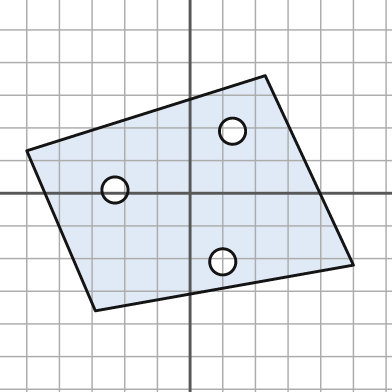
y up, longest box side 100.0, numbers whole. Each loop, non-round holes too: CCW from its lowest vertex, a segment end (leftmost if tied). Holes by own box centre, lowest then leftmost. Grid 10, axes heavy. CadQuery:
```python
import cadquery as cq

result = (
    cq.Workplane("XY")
    .moveTo(-29.0, -36.0)
    .lineTo(50.0, -22.0)
    .lineTo(23.0, 36.0)
    .lineTo(-50.0, 13.0)
    .close()
    .moveTo(10.0, -21.0)
    .circle(4.0)
    .moveTo(-23.0, 1.0)
    .circle(4.0)
    .moveTo(13.0, 19.0)
    .circle(4.0)
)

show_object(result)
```